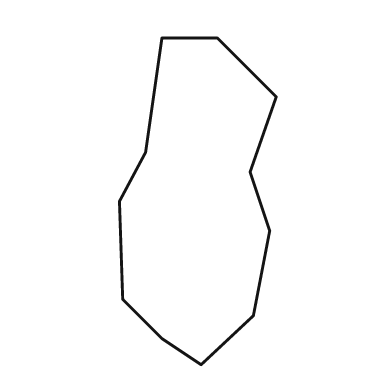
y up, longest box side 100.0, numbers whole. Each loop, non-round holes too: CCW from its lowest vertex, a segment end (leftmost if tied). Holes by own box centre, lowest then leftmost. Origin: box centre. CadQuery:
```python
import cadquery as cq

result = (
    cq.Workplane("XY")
    .moveTo(1.0, -50.0)
    .lineTo(17.0, -35.0)
    .lineTo(22.0, -9.0)
    .lineTo(16.0, 9.0)
    .lineTo(24.0, 32.0)
    .lineTo(6.0, 50.0)
    .lineTo(-11.0, 50.0)
    .lineTo(-16.0, 15.0)
    .lineTo(-24.0, 0.0)
    .lineTo(-23.0, -30.0)
    .lineTo(-11.0, -42.0)
    .close()
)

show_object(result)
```